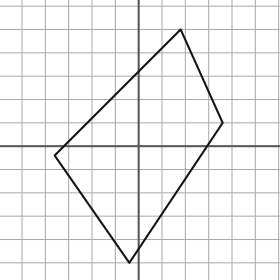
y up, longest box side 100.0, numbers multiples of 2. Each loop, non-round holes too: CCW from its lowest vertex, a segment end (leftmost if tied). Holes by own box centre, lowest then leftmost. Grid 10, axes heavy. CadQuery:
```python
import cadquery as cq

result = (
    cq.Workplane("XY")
    .moveTo(-4.0, -50.0)
    .lineTo(36.0, 10.0)
    .lineTo(18.0, 50.0)
    .lineTo(-36.0, -4.0)
    .close()
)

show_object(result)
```